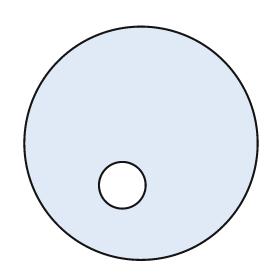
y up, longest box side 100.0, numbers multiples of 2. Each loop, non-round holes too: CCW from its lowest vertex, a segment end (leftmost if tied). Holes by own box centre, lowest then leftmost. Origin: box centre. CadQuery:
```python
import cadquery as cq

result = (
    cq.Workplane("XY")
    .moveTo(0.0, 0.0)
    .circle(50.0)
    .moveTo(-8.0, -18.0)
    .circle(10.0)
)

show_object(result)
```